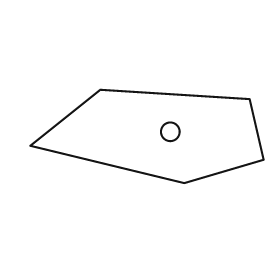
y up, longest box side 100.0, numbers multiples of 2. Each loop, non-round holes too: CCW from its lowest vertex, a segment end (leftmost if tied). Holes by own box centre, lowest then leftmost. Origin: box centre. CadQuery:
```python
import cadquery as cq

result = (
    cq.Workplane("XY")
    .moveTo(16.0, -20.0)
    .lineTo(50.0, -10.0)
    .lineTo(44.0, 16.0)
    .lineTo(-20.0, 20.0)
    .lineTo(-50.0, -4.0)
    .close()
    .moveTo(10.0, 2.0)
    .circle(4.0)
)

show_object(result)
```